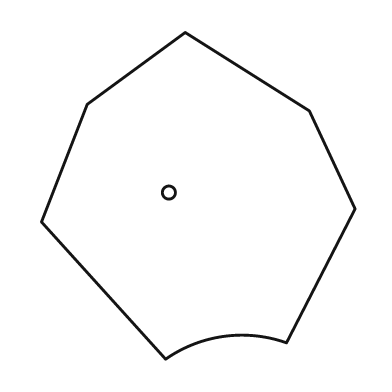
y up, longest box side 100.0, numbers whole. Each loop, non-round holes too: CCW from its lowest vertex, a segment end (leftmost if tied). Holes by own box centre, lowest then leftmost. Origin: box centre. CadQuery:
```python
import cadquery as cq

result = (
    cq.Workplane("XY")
    .moveTo(-10.0, -50.0)
    .threePointArc((8.0, -43.0), (27.0, -45.0))
    .lineTo(48.0, -4.0)
    .lineTo(34.0, 26.0)
    .lineTo(-4.0, 50.0)
    .lineTo(-34.0, 28.0)
    .lineTo(-48.0, -8.0)
    .close()
    .moveTo(-9.0, 1.0)
    .circle(2.0)
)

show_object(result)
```